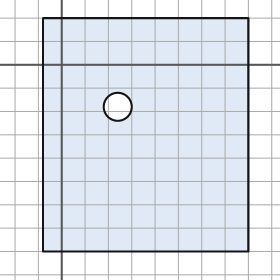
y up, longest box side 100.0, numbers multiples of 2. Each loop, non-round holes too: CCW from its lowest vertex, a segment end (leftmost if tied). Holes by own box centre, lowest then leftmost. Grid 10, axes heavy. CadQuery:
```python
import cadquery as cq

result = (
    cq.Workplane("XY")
    .moveTo(-8.0, -80.0)
    .lineTo(80.0, -80.0)
    .lineTo(80.0, 20.0)
    .lineTo(-8.0, 20.0)
    .close()
    .moveTo(24.0, -18.0)
    .circle(6.0)
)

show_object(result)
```